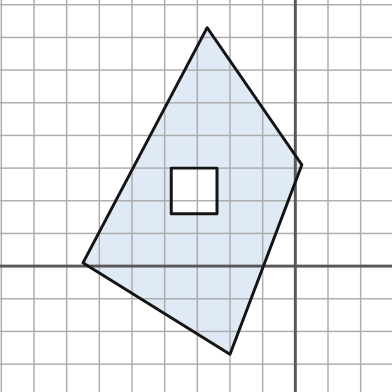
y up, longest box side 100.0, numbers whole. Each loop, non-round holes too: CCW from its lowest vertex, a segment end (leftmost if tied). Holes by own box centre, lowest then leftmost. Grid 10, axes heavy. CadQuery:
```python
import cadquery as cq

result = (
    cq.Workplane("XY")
    .moveTo(-20.0, -27.0)
    .lineTo(2.0, 31.0)
    .lineTo(-27.0, 73.0)
    .lineTo(-65.0, 1.0)
    .close()
    .moveTo(-38.0, 16.0)
    .lineTo(-24.0, 16.0)
    .lineTo(-24.0, 30.0)
    .lineTo(-38.0, 30.0)
    .close()
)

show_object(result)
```